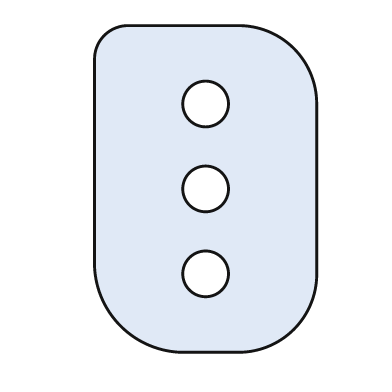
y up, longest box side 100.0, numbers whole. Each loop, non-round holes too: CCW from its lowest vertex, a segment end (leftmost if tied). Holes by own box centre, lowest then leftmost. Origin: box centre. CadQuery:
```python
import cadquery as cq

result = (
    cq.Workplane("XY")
    .moveTo(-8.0, -50.0)
    .lineTo(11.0, -50.0)
    .threePointArc((27.0, -43.0), (34.0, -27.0))
    .lineTo(34.0, 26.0)
    .threePointArc((27.0, 43.0), (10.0, 50.0))
    .lineTo(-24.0, 50.0)
    .threePointArc((-31.0, 47.0), (-34.0, 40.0))
    .lineTo(-34.0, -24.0)
    .threePointArc((-26.0, -42.0), (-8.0, -50.0))
    .close()
    .moveTo(0.0, -26.0)
    .circle(7.0)
    .moveTo(0.0, 0.0)
    .circle(7.0)
    .moveTo(0.0, 26.0)
    .circle(7.0)
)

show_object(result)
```